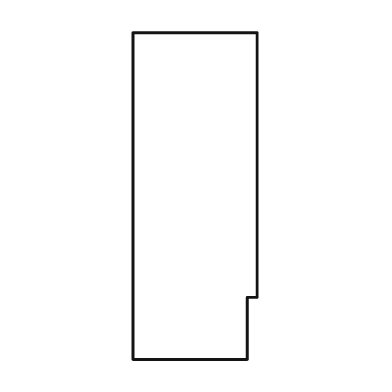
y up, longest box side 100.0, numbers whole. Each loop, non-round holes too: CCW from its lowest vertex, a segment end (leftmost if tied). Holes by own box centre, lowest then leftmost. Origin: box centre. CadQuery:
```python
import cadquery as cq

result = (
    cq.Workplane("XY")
    .moveTo(-19.0, -50.0)
    .lineTo(16.0, -50.0)
    .lineTo(16.0, -31.0)
    .lineTo(19.0, -31.0)
    .lineTo(19.0, 50.0)
    .lineTo(-19.0, 50.0)
    .close()
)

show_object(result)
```